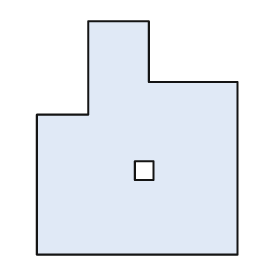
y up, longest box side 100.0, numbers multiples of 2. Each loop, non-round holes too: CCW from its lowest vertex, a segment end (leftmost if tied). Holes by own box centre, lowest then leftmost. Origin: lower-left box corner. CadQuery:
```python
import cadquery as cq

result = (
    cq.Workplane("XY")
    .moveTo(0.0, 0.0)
    .lineTo(86.0, 0.0)
    .lineTo(86.0, 74.0)
    .lineTo(48.0, 74.0)
    .lineTo(48.0, 100.0)
    .lineTo(22.0, 100.0)
    .lineTo(22.0, 60.0)
    .lineTo(0.0, 60.0)
    .close()
    .moveTo(42.0, 32.0)
    .lineTo(50.0, 32.0)
    .lineTo(50.0, 40.0)
    .lineTo(42.0, 40.0)
    .close()
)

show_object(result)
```